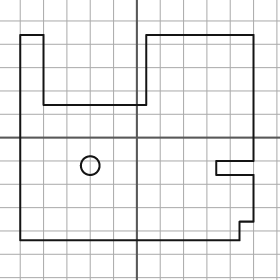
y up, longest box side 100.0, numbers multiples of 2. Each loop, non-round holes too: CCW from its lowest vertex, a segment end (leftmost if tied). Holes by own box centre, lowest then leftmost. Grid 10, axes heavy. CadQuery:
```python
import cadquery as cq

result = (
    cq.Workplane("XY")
    .moveTo(-50.0, -44.0)
    .lineTo(44.0, -44.0)
    .lineTo(44.0, -36.0)
    .lineTo(50.0, -36.0)
    .lineTo(50.0, -16.0)
    .lineTo(34.0, -16.0)
    .lineTo(34.0, -10.0)
    .lineTo(50.0, -10.0)
    .lineTo(50.0, 44.0)
    .lineTo(4.0, 44.0)
    .lineTo(4.0, 14.0)
    .lineTo(-40.0, 14.0)
    .lineTo(-40.0, 44.0)
    .lineTo(-50.0, 44.0)
    .close()
    .moveTo(-20.0, -12.0)
    .circle(4.0)
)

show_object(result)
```